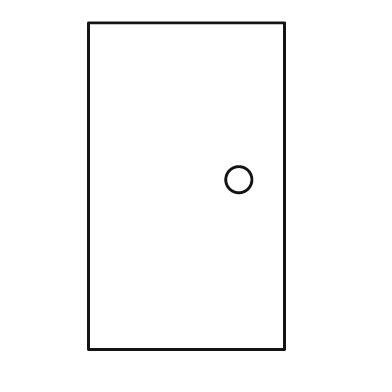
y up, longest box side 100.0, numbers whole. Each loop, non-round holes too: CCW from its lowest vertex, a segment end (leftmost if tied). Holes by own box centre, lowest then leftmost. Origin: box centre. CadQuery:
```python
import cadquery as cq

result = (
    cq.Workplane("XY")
    .moveTo(-30.0, -50.0)
    .lineTo(30.0, -50.0)
    .lineTo(30.0, 50.0)
    .lineTo(-30.0, 50.0)
    .close()
    .moveTo(16.0, 2.0)
    .circle(4.0)
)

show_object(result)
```